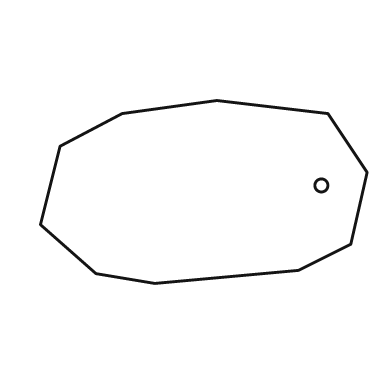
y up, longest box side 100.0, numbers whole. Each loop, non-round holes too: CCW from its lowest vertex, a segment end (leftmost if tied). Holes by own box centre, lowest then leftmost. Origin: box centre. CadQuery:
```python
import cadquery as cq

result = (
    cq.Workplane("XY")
    .moveTo(-15.0, -28.0)
    .lineTo(29.0, -24.0)
    .lineTo(45.0, -16.0)
    .lineTo(50.0, 6.0)
    .lineTo(38.0, 24.0)
    .lineTo(4.0, 28.0)
    .lineTo(-25.0, 24.0)
    .lineTo(-44.0, 14.0)
    .lineTo(-50.0, -10.0)
    .lineTo(-33.0, -25.0)
    .close()
    .moveTo(36.0, 2.0)
    .circle(2.0)
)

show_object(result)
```